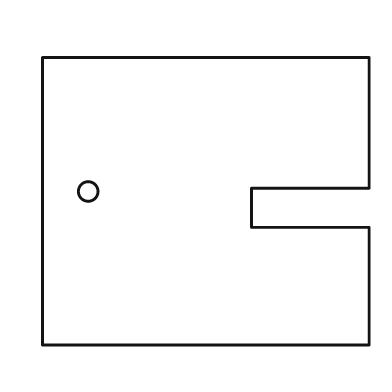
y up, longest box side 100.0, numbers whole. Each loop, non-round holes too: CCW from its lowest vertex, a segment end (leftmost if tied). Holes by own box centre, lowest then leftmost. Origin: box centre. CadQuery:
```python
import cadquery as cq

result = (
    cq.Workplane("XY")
    .moveTo(-50.0, -44.0)
    .lineTo(50.0, -44.0)
    .lineTo(50.0, -8.0)
    .lineTo(14.0, -8.0)
    .lineTo(14.0, 4.0)
    .lineTo(50.0, 4.0)
    .lineTo(50.0, 44.0)
    .lineTo(-50.0, 44.0)
    .close()
    .moveTo(-36.0, 3.0)
    .circle(3.0)
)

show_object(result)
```